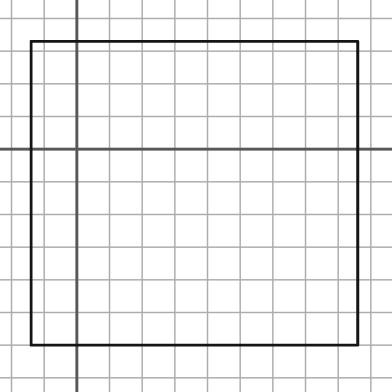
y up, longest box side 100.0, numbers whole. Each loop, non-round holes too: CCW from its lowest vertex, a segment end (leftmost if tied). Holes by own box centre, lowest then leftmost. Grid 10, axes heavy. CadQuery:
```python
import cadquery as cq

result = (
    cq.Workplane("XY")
    .moveTo(-14.0, -60.0)
    .lineTo(86.0, -60.0)
    .lineTo(86.0, 33.0)
    .lineTo(-14.0, 33.0)
    .close()
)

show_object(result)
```